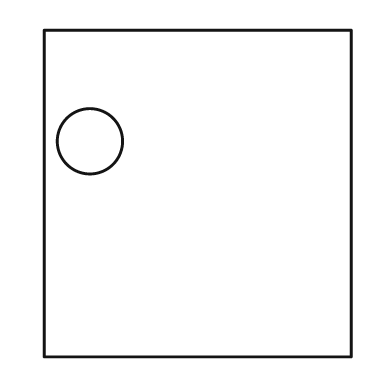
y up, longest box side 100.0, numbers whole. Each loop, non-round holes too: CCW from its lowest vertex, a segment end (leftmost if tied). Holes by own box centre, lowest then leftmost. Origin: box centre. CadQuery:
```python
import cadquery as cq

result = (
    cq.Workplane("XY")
    .moveTo(-47.0, -50.0)
    .lineTo(47.0, -50.0)
    .lineTo(47.0, 50.0)
    .lineTo(-47.0, 50.0)
    .close()
    .moveTo(-33.0, 16.0)
    .circle(10.0)
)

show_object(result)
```